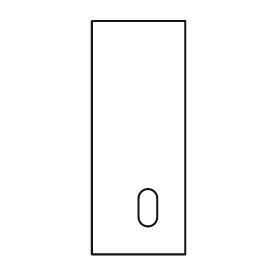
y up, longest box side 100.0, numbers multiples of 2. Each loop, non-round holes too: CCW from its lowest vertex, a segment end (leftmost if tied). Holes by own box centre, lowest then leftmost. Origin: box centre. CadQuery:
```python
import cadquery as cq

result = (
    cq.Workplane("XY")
    .moveTo(-20.0, -50.0)
    .lineTo(20.0, -50.0)
    .lineTo(20.0, 50.0)
    .lineTo(-20.0, 50.0)
    .close()
    .moveTo(0.0, -34.0)
    .threePointArc((4.0, -38.0), (8.0, -34.0))
    .lineTo(8.0, -26.0)
    .threePointArc((4.0, -22.0), (0.0, -26.0))
    .close()
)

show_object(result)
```